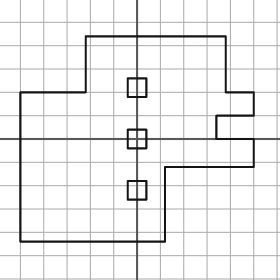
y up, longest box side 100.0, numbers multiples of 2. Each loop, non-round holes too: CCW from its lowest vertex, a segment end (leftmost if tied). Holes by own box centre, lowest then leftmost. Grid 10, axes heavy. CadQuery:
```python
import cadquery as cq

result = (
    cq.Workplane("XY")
    .moveTo(-50.0, -44.0)
    .lineTo(12.0, -44.0)
    .lineTo(12.0, -12.0)
    .lineTo(50.0, -12.0)
    .lineTo(50.0, 0.0)
    .lineTo(34.0, 0.0)
    .lineTo(34.0, 10.0)
    .lineTo(50.0, 10.0)
    .lineTo(50.0, 20.0)
    .lineTo(38.0, 20.0)
    .lineTo(38.0, 44.0)
    .lineTo(-22.0, 44.0)
    .lineTo(-22.0, 20.0)
    .lineTo(-50.0, 20.0)
    .close()
    .moveTo(-4.0, -26.0)
    .lineTo(4.0, -26.0)
    .lineTo(4.0, -18.0)
    .lineTo(-4.0, -18.0)
    .close()
    .moveTo(-4.0, -4.0)
    .lineTo(4.0, -4.0)
    .lineTo(4.0, 4.0)
    .lineTo(-4.0, 4.0)
    .close()
    .moveTo(-4.0, 18.0)
    .lineTo(4.0, 18.0)
    .lineTo(4.0, 26.0)
    .lineTo(-4.0, 26.0)
    .close()
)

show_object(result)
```